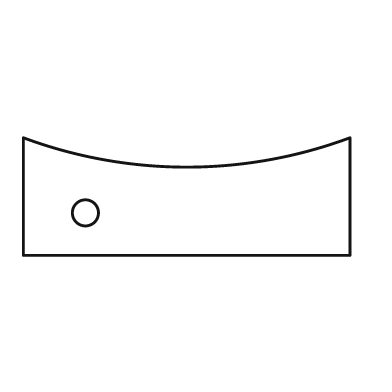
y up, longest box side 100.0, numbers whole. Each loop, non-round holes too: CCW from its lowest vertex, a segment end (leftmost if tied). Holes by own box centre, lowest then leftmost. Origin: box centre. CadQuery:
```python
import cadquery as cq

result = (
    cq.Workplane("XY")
    .moveTo(-50.0, -18.0)
    .lineTo(50.0, -18.0)
    .lineTo(50.0, 18.0)
    .threePointArc((0.0, 9.0), (-50.0, 18.0))
    .close()
    .moveTo(-31.0, -5.0)
    .circle(4.0)
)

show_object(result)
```